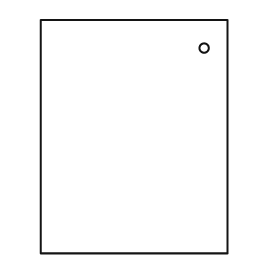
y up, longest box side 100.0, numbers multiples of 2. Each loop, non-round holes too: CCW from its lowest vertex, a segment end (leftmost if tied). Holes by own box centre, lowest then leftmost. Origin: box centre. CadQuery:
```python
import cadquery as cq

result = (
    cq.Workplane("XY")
    .moveTo(-40.0, -50.0)
    .lineTo(40.0, -50.0)
    .lineTo(40.0, 50.0)
    .lineTo(-40.0, 50.0)
    .close()
    .moveTo(30.0, 38.0)
    .circle(2.0)
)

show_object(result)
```